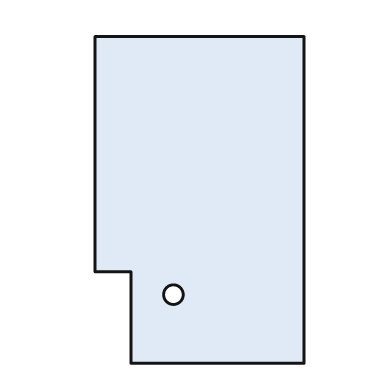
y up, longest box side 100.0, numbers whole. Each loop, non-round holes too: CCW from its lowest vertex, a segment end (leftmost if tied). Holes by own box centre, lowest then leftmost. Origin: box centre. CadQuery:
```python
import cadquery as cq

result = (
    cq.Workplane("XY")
    .moveTo(-21.0, -50.0)
    .lineTo(32.0, -50.0)
    .lineTo(32.0, 50.0)
    .lineTo(-32.0, 50.0)
    .lineTo(-32.0, -22.0)
    .lineTo(-21.0, -22.0)
    .close()
    .moveTo(-8.0, -29.0)
    .circle(3.0)
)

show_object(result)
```